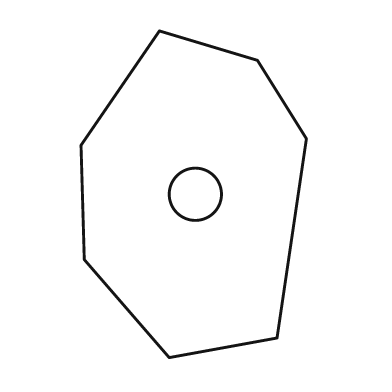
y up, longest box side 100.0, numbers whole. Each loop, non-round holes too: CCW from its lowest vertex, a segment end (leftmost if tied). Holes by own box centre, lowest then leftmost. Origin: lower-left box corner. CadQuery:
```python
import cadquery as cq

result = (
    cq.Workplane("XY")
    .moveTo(27.0, 0.0)
    .lineTo(60.0, 6.0)
    .lineTo(69.0, 67.0)
    .lineTo(54.0, 91.0)
    .lineTo(24.0, 100.0)
    .lineTo(0.0, 65.0)
    .lineTo(1.0, 30.0)
    .close()
    .moveTo(35.0, 50.0)
    .circle(8.0)
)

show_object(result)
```